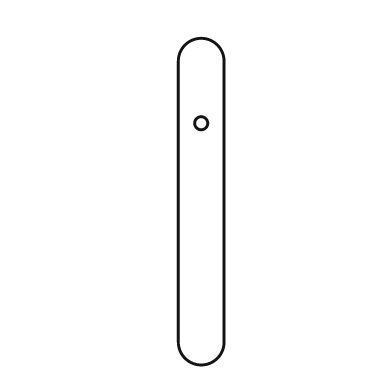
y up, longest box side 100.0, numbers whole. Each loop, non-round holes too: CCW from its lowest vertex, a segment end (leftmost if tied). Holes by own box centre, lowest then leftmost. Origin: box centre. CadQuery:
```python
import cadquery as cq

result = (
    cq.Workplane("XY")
    .moveTo(-7.0, -43.0)
    .threePointArc((0.0, -50.0), (7.0, -43.0))
    .lineTo(7.0, 43.0)
    .threePointArc((0.0, 50.0), (-7.0, 43.0))
    .close()
    .moveTo(0.0, 24.0)
    .circle(2.0)
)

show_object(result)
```